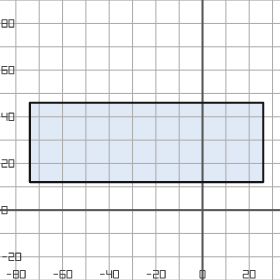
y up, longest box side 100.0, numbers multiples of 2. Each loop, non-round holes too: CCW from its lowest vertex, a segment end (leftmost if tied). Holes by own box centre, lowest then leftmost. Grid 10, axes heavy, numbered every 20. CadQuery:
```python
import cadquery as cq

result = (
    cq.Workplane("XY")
    .moveTo(-74.0, 12.0)
    .lineTo(26.0, 12.0)
    .lineTo(26.0, 46.0)
    .lineTo(-74.0, 46.0)
    .close()
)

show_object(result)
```